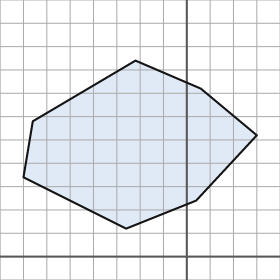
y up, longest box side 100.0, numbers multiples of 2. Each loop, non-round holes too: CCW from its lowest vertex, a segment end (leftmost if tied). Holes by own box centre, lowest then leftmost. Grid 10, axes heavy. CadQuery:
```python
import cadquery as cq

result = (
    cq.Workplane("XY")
    .moveTo(-26.0, 12.0)
    .lineTo(4.0, 24.0)
    .lineTo(30.0, 52.0)
    .lineTo(6.0, 72.0)
    .lineTo(-22.0, 84.0)
    .lineTo(-66.0, 58.0)
    .lineTo(-70.0, 34.0)
    .close()
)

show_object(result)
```